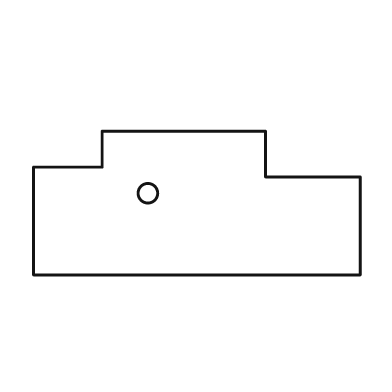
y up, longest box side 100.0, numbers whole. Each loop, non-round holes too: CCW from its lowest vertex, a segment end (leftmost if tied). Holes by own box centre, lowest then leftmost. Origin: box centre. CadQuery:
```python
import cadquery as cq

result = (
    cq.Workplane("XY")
    .moveTo(-50.0, -22.0)
    .lineTo(50.0, -22.0)
    .lineTo(50.0, 8.0)
    .lineTo(21.0, 8.0)
    .lineTo(21.0, 22.0)
    .lineTo(-29.0, 22.0)
    .lineTo(-29.0, 11.0)
    .lineTo(-50.0, 11.0)
    .close()
    .moveTo(-15.0, 3.0)
    .circle(3.0)
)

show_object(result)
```